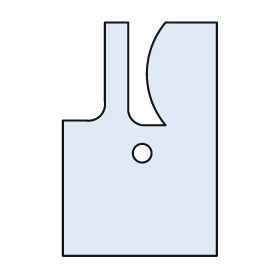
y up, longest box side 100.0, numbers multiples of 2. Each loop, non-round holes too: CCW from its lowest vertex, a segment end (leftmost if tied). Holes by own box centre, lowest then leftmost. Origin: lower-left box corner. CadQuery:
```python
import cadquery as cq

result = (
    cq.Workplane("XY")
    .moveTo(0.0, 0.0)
    .lineTo(66.0, 0.0)
    .lineTo(66.0, 100.0)
    .lineTo(44.0, 100.0)
    .threePointArc((36.0, 78.0), (44.0, 56.0))
    .lineTo(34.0, 56.0)
    .threePointArc((30.0, 58.0), (28.0, 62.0))
    .lineTo(28.0, 100.0)
    .lineTo(18.0, 100.0)
    .lineTo(18.0, 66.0)
    .threePointArc((16.0, 60.0), (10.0, 58.0))
    .lineTo(0.0, 58.0)
    .close()
    .moveTo(34.0, 44.0)
    .circle(4.0)
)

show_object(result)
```